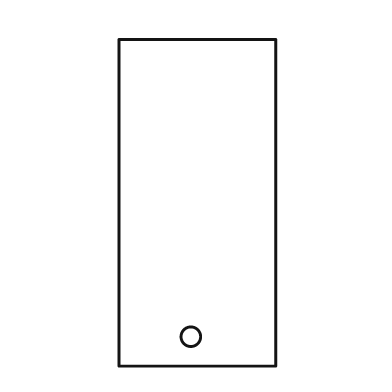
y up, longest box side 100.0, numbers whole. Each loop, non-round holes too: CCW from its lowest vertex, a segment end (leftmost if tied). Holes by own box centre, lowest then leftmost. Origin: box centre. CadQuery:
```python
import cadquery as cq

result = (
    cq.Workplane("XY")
    .moveTo(-24.0, -50.0)
    .lineTo(24.0, -50.0)
    .lineTo(24.0, 50.0)
    .lineTo(-24.0, 50.0)
    .close()
    .moveTo(-2.0, -41.0)
    .circle(3.0)
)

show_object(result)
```